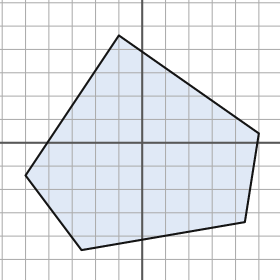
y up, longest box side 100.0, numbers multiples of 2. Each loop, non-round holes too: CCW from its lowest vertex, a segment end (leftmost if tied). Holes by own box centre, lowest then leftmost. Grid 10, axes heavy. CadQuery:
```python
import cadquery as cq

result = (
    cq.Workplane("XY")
    .moveTo(-26.0, -46.0)
    .lineTo(44.0, -34.0)
    .lineTo(50.0, 4.0)
    .lineTo(-10.0, 46.0)
    .lineTo(-50.0, -14.0)
    .close()
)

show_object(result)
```